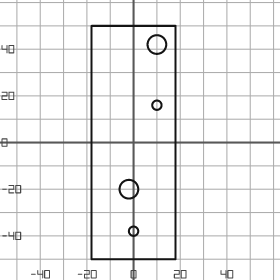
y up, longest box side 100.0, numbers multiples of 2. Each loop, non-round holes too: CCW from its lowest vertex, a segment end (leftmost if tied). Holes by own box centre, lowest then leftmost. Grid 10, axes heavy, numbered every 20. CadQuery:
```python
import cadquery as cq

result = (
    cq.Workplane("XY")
    .moveTo(-18.0, -50.0)
    .lineTo(18.0, -50.0)
    .lineTo(18.0, 50.0)
    .lineTo(-18.0, 50.0)
    .close()
    .moveTo(0.0, -38.0)
    .circle(2.0)
    .moveTo(-2.0, -20.0)
    .circle(4.0)
    .moveTo(10.0, 16.0)
    .circle(2.0)
    .moveTo(10.0, 42.0)
    .circle(4.0)
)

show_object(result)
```